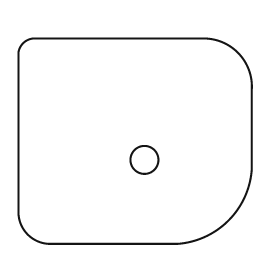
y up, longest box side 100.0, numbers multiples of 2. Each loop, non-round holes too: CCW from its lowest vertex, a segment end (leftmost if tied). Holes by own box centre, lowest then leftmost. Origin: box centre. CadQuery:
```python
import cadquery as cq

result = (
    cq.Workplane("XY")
    .moveTo(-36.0, -44.0)
    .lineTo(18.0, -44.0)
    .threePointArc((40.0, -34.0), (50.0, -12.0))
    .lineTo(50.0, 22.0)
    .threePointArc((44.0, 38.0), (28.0, 44.0))
    .lineTo(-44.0, 44.0)
    .threePointArc((-48.0, 42.0), (-50.0, 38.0))
    .lineTo(-50.0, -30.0)
    .threePointArc((-46.0, -40.0), (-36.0, -44.0))
    .close()
    .moveTo(4.0, -8.0)
    .circle(6.0)
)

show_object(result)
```